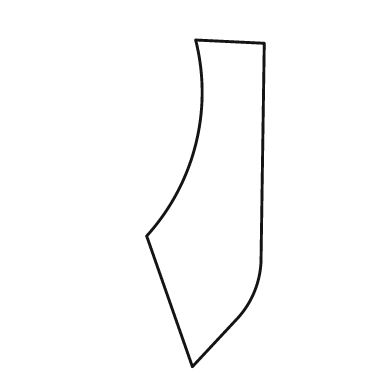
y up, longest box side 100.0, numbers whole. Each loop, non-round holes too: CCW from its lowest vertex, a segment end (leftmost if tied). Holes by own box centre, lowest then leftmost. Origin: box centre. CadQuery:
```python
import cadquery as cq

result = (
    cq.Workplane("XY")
    .moveTo(-4.0, -50.0)
    .lineTo(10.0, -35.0)
    .threePointArc((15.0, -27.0), (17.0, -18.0))
    .lineTo(18.0, 49.0)
    .lineTo(-3.0, 50.0)
    .threePointArc((-3.0, 18.0), (-18.0, -10.0))
    .close()
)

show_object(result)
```